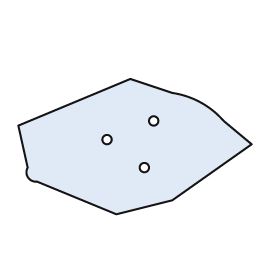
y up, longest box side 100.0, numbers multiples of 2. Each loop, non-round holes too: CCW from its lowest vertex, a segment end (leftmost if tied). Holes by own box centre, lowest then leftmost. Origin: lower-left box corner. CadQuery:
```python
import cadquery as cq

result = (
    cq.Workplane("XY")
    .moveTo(42.0, 0.0)
    .lineTo(66.0, 6.0)
    .lineTo(100.0, 30.0)
    .lineTo(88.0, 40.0)
    .threePointArc((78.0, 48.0), (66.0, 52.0))
    .lineTo(48.0, 58.0)
    .lineTo(0.0, 38.0)
    .lineTo(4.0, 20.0)
    .threePointArc((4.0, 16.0), (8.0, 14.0))
    .close()
    .moveTo(54.0, 20.0)
    .circle(2.0)
    .moveTo(38.0, 32.0)
    .circle(2.0)
    .moveTo(58.0, 40.0)
    .circle(2.0)
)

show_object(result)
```